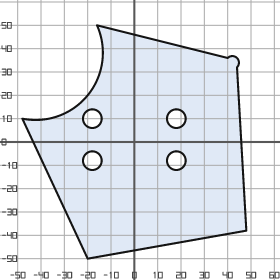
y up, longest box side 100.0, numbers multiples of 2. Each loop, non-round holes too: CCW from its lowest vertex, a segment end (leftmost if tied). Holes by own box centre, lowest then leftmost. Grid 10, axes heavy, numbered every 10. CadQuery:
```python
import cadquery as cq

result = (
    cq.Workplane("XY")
    .moveTo(-20.0, -50.0)
    .lineTo(48.0, -38.0)
    .lineTo(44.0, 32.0)
    .threePointArc((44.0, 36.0), (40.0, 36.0))
    .lineTo(-16.0, 50.0)
    .threePointArc((-20.0, 20.0), (-48.0, 10.0))
    .close()
    .moveTo(-18.0, -8.0)
    .circle(4.0)
    .moveTo(18.0, -8.0)
    .circle(4.0)
    .moveTo(-18.0, 10.0)
    .circle(4.0)
    .moveTo(18.0, 10.0)
    .circle(4.0)
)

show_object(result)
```